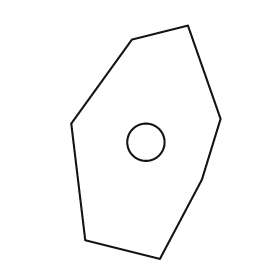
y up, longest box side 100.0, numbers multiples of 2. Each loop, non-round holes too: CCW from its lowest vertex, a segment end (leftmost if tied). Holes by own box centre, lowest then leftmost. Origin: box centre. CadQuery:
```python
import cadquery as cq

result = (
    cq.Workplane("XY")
    .moveTo(6.0, -50.0)
    .lineTo(24.0, -16.0)
    .lineTo(32.0, 10.0)
    .lineTo(18.0, 50.0)
    .lineTo(-6.0, 44.0)
    .lineTo(-32.0, 8.0)
    .lineTo(-26.0, -42.0)
    .close()
    .moveTo(0.0, 0.0)
    .circle(8.0)
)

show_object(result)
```